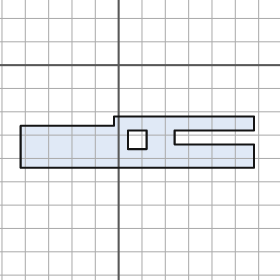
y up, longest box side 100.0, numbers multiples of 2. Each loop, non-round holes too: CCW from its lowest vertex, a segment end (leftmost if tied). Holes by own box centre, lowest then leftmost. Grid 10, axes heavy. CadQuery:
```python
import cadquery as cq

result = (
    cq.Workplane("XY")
    .moveTo(-42.0, -44.0)
    .lineTo(58.0, -44.0)
    .lineTo(58.0, -34.0)
    .lineTo(24.0, -34.0)
    .lineTo(24.0, -28.0)
    .lineTo(58.0, -28.0)
    .lineTo(58.0, -22.0)
    .lineTo(-2.0, -22.0)
    .lineTo(-2.0, -26.0)
    .lineTo(-42.0, -26.0)
    .close()
    .moveTo(4.0, -36.0)
    .lineTo(12.0, -36.0)
    .lineTo(12.0, -28.0)
    .lineTo(4.0, -28.0)
    .close()
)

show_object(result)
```